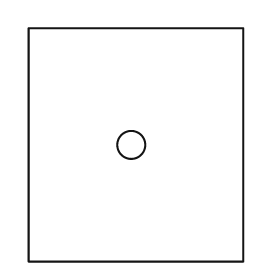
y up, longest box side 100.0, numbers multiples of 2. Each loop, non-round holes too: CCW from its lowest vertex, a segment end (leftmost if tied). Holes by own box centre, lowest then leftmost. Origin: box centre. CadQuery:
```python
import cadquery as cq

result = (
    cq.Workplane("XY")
    .moveTo(-46.0, -50.0)
    .lineTo(46.0, -50.0)
    .lineTo(46.0, 50.0)
    .lineTo(-46.0, 50.0)
    .close()
    .moveTo(-2.0, 0.0)
    .circle(6.0)
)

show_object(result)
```